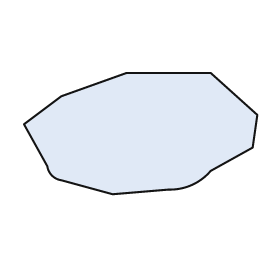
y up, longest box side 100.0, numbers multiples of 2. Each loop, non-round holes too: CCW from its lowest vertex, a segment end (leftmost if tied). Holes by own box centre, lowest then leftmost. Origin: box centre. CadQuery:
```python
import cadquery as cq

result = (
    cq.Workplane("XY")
    .moveTo(-12.0, -26.0)
    .lineTo(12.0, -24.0)
    .threePointArc((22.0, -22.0), (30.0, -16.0))
    .lineTo(48.0, -6.0)
    .lineTo(50.0, 8.0)
    .lineTo(30.0, 26.0)
    .lineTo(-6.0, 26.0)
    .lineTo(-34.0, 16.0)
    .lineTo(-50.0, 4.0)
    .lineTo(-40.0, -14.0)
    .threePointArc((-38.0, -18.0), (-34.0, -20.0))
    .close()
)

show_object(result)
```